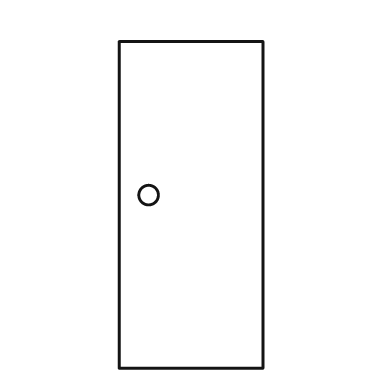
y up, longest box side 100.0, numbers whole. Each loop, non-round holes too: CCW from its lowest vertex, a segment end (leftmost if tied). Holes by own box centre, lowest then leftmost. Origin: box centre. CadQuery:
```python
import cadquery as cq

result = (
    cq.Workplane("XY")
    .moveTo(-22.0, -50.0)
    .lineTo(22.0, -50.0)
    .lineTo(22.0, 50.0)
    .lineTo(-22.0, 50.0)
    .close()
    .moveTo(-13.0, 3.0)
    .circle(3.0)
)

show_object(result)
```